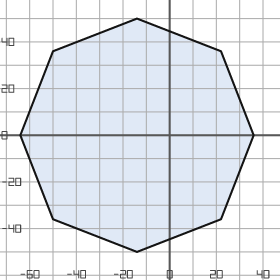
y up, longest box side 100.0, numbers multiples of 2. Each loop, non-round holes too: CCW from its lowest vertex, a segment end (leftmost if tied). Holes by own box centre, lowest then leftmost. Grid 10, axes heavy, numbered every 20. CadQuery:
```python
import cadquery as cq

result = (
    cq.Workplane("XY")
    .moveTo(-14.0, -50.0)
    .lineTo(22.0, -36.0)
    .lineTo(36.0, 0.0)
    .lineTo(22.0, 36.0)
    .lineTo(-14.0, 50.0)
    .lineTo(-50.0, 36.0)
    .lineTo(-64.0, 0.0)
    .lineTo(-50.0, -36.0)
    .close()
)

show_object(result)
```